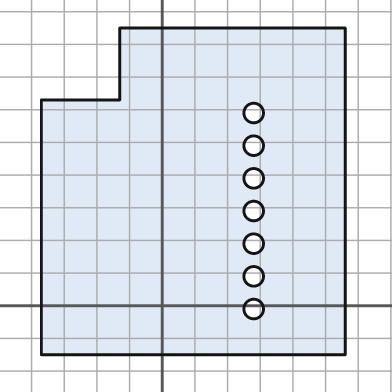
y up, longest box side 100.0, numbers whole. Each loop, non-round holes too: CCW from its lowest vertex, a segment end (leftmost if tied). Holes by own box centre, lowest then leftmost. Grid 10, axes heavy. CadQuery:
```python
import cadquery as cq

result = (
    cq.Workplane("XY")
    .moveTo(-37.0, -15.0)
    .lineTo(56.0, -15.0)
    .lineTo(56.0, 85.0)
    .lineTo(-13.0, 85.0)
    .lineTo(-13.0, 63.0)
    .lineTo(-37.0, 63.0)
    .close()
    .moveTo(28.0, -1.0)
    .circle(3.0)
    .moveTo(28.0, 9.0)
    .circle(3.0)
    .moveTo(28.0, 19.0)
    .circle(3.0)
    .moveTo(28.0, 29.0)
    .circle(3.0)
    .moveTo(28.0, 39.0)
    .circle(3.0)
    .moveTo(28.0, 49.0)
    .circle(3.0)
    .moveTo(28.0, 59.0)
    .circle(3.0)
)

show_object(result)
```